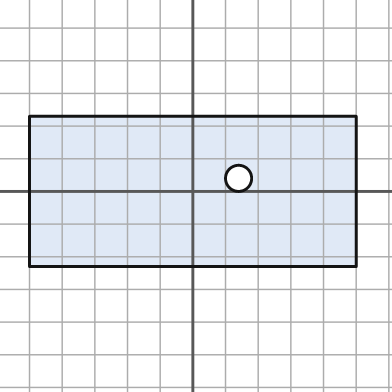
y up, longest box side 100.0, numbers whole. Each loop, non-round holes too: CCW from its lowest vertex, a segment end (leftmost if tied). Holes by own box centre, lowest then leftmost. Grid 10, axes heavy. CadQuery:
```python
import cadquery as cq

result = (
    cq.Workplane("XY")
    .moveTo(-50.0, -23.0)
    .lineTo(50.0, -23.0)
    .lineTo(50.0, 23.0)
    .lineTo(-50.0, 23.0)
    .close()
    .moveTo(14.0, 4.0)
    .circle(4.0)
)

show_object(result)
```